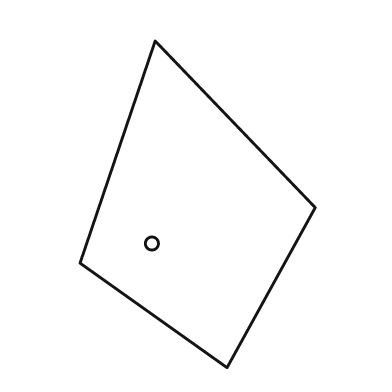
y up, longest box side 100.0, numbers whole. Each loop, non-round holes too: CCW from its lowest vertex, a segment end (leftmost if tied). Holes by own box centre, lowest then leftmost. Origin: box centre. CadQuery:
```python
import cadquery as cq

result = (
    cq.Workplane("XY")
    .moveTo(9.0, -50.0)
    .lineTo(36.0, -1.0)
    .lineTo(-13.0, 50.0)
    .lineTo(-36.0, -18.0)
    .close()
    .moveTo(-14.0, -12.0)
    .circle(2.0)
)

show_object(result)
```